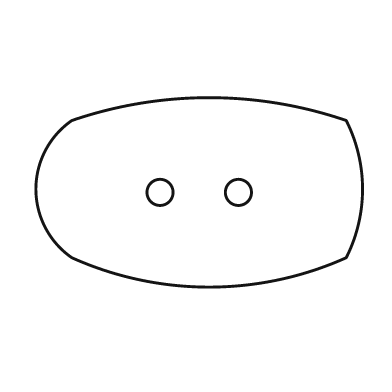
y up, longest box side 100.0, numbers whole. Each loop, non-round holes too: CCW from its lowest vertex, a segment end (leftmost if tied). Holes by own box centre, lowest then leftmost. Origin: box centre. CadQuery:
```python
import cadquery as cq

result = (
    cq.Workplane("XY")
    .moveTo(-39.0, -20.0)
    .threePointArc((3.0, -29.0), (45.0, -20.0))
    .threePointArc((50.0, 1.0), (45.0, 22.0))
    .threePointArc((3.0, 29.0), (-39.0, 22.0))
    .threePointArc((-50.0, 1.0), (-39.0, -20.0))
    .close()
    .moveTo(-12.0, 0.0)
    .circle(4.0)
    .moveTo(12.0, 0.0)
    .circle(4.0)
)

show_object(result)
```